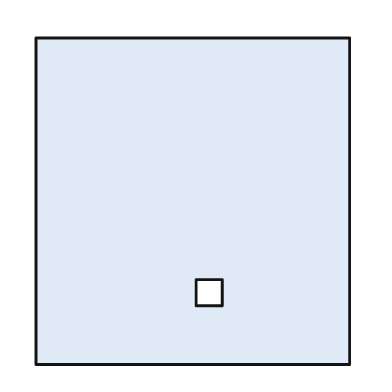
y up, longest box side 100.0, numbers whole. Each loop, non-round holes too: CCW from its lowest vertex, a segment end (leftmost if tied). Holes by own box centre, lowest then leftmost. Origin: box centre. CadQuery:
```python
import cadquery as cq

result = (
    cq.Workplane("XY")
    .moveTo(-48.0, -50.0)
    .lineTo(48.0, -50.0)
    .lineTo(48.0, 50.0)
    .lineTo(-48.0, 50.0)
    .close()
    .moveTo(1.0, -32.0)
    .lineTo(9.0, -32.0)
    .lineTo(9.0, -24.0)
    .lineTo(1.0, -24.0)
    .close()
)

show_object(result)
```